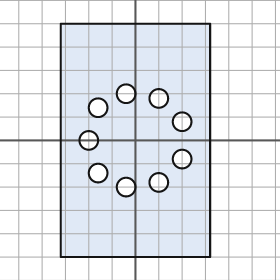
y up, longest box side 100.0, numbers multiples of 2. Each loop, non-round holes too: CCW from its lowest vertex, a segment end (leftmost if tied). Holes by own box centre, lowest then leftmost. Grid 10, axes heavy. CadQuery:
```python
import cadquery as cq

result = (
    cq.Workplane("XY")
    .moveTo(-32.0, -50.0)
    .lineTo(32.0, -50.0)
    .lineTo(32.0, 50.0)
    .lineTo(-32.0, 50.0)
    .close()
    .moveTo(-4.0, -20.0)
    .circle(4.0)
    .moveTo(10.0, -18.0)
    .circle(4.0)
    .moveTo(-16.0, -14.0)
    .circle(4.0)
    .moveTo(20.0, -8.0)
    .circle(4.0)
    .moveTo(-20.0, 0.0)
    .circle(4.0)
    .moveTo(20.0, 8.0)
    .circle(4.0)
    .moveTo(-16.0, 14.0)
    .circle(4.0)
    .moveTo(10.0, 18.0)
    .circle(4.0)
    .moveTo(-4.0, 20.0)
    .circle(4.0)
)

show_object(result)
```